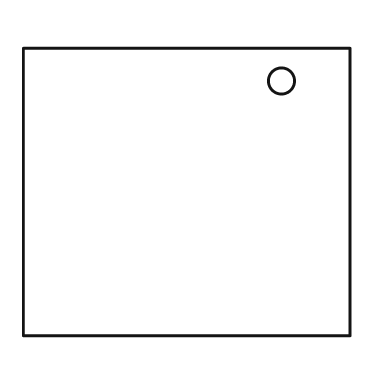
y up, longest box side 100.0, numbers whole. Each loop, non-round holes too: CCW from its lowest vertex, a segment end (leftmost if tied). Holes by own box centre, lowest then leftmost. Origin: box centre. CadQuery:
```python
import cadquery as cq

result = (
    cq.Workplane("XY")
    .moveTo(-50.0, -44.0)
    .lineTo(50.0, -44.0)
    .lineTo(50.0, 44.0)
    .lineTo(-50.0, 44.0)
    .close()
    .moveTo(29.0, 34.0)
    .circle(4.0)
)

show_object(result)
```